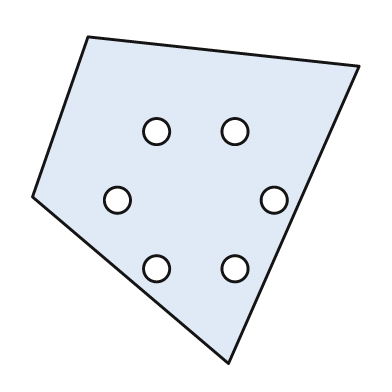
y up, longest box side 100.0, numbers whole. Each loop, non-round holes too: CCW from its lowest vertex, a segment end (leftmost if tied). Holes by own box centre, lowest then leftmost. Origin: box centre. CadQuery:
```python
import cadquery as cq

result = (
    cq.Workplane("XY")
    .moveTo(10.0, -50.0)
    .lineTo(50.0, 41.0)
    .lineTo(-33.0, 50.0)
    .lineTo(-50.0, 1.0)
    .close()
    .moveTo(-12.0, -21.0)
    .circle(4.0)
    .moveTo(12.0, -21.0)
    .circle(4.0)
    .moveTo(-24.0, 0.0)
    .circle(4.0)
    .moveTo(24.0, 0.0)
    .circle(4.0)
    .moveTo(-12.0, 21.0)
    .circle(4.0)
    .moveTo(12.0, 21.0)
    .circle(4.0)
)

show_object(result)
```